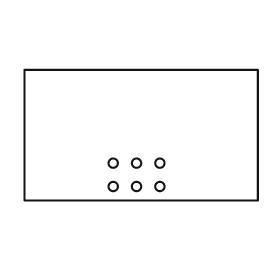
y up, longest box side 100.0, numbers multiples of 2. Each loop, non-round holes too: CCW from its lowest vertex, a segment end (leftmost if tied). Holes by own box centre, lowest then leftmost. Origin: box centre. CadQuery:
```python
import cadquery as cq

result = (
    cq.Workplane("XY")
    .moveTo(-50.0, -28.0)
    .lineTo(50.0, -28.0)
    .lineTo(50.0, 28.0)
    .lineTo(-50.0, 28.0)
    .close()
    .moveTo(-12.0, -22.0)
    .circle(2.0)
    .moveTo(-2.0, -22.0)
    .circle(2.0)
    .moveTo(8.0, -22.0)
    .circle(2.0)
    .moveTo(-12.0, -12.0)
    .circle(2.0)
    .moveTo(-2.0, -12.0)
    .circle(2.0)
    .moveTo(8.0, -12.0)
    .circle(2.0)
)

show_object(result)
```